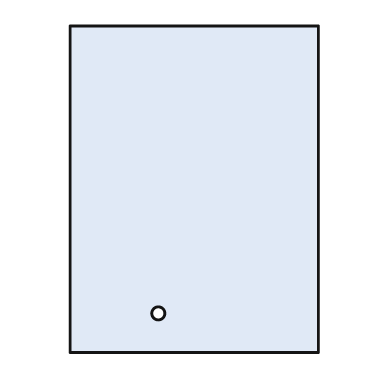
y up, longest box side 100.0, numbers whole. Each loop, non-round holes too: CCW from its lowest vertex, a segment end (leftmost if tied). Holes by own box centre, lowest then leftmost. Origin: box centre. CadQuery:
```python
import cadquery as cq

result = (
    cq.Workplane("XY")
    .moveTo(-38.0, -50.0)
    .lineTo(38.0, -50.0)
    .lineTo(38.0, 50.0)
    .lineTo(-38.0, 50.0)
    .close()
    .moveTo(-11.0, -38.0)
    .circle(2.0)
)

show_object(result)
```